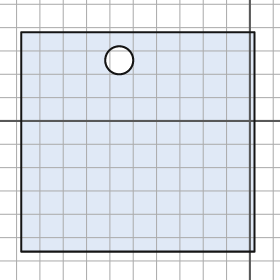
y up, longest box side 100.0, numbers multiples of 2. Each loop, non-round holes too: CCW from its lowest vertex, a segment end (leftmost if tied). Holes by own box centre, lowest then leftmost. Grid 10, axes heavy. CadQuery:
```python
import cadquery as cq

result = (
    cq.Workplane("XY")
    .moveTo(-98.0, -56.0)
    .lineTo(2.0, -56.0)
    .lineTo(2.0, 38.0)
    .lineTo(-98.0, 38.0)
    .close()
    .moveTo(-56.0, 26.0)
    .circle(6.0)
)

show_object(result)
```